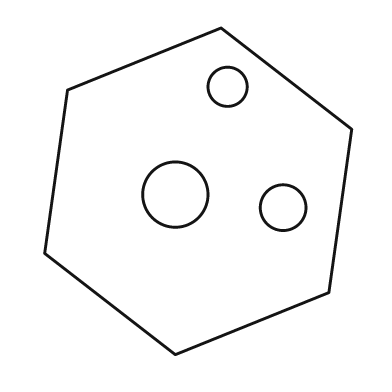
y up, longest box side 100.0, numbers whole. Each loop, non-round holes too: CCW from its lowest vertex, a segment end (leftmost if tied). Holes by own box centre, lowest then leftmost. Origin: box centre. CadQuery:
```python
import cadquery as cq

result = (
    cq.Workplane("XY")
    .moveTo(-7.0, -50.0)
    .lineTo(40.0, -31.0)
    .lineTo(47.0, 19.0)
    .lineTo(7.0, 50.0)
    .lineTo(-40.0, 31.0)
    .lineTo(-47.0, -19.0)
    .close()
    .moveTo(26.0, -5.0)
    .circle(7.0)
    .moveTo(-7.0, -1.0)
    .circle(10.0)
    .moveTo(9.0, 32.0)
    .circle(6.0)
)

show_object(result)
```